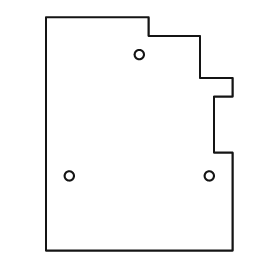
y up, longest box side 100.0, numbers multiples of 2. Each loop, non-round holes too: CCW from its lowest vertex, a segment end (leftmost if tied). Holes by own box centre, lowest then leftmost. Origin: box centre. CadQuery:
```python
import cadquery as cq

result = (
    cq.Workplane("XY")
    .moveTo(-40.0, -50.0)
    .lineTo(40.0, -50.0)
    .lineTo(40.0, -8.0)
    .lineTo(32.0, -8.0)
    .lineTo(32.0, 16.0)
    .lineTo(40.0, 16.0)
    .lineTo(40.0, 24.0)
    .lineTo(26.0, 24.0)
    .lineTo(26.0, 42.0)
    .lineTo(4.0, 42.0)
    .lineTo(4.0, 50.0)
    .lineTo(-40.0, 50.0)
    .close()
    .moveTo(-30.0, -18.0)
    .circle(2.0)
    .moveTo(30.0, -18.0)
    .circle(2.0)
    .moveTo(0.0, 34.0)
    .circle(2.0)
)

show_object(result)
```